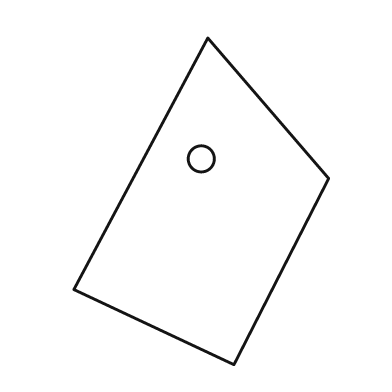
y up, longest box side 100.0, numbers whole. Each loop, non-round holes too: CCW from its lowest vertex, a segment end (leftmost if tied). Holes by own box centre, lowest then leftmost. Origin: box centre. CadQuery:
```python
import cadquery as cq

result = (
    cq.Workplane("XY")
    .moveTo(10.0, -50.0)
    .lineTo(39.0, 7.0)
    .lineTo(2.0, 50.0)
    .lineTo(-39.0, -27.0)
    .close()
    .moveTo(0.0, 13.0)
    .circle(4.0)
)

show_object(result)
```